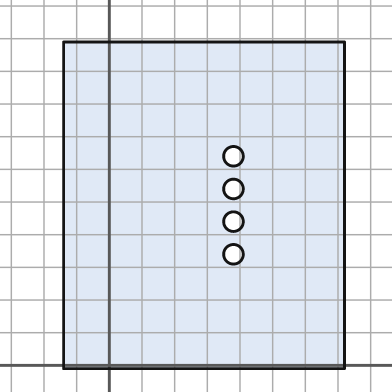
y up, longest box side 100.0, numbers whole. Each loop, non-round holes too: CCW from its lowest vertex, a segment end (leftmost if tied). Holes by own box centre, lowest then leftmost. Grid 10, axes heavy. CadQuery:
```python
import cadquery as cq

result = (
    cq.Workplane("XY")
    .moveTo(-14.0, -1.0)
    .lineTo(72.0, -1.0)
    .lineTo(72.0, 99.0)
    .lineTo(-14.0, 99.0)
    .close()
    .moveTo(38.0, 34.0)
    .circle(3.0)
    .moveTo(38.0, 44.0)
    .circle(3.0)
    .moveTo(38.0, 54.0)
    .circle(3.0)
    .moveTo(38.0, 64.0)
    .circle(3.0)
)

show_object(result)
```